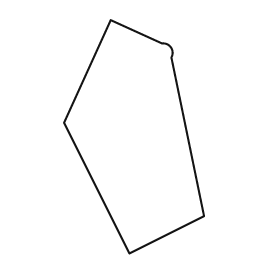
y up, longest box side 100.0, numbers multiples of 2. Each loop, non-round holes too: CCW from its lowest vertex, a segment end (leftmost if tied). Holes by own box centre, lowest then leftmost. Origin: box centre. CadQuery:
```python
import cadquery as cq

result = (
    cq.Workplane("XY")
    .moveTo(-2.0, -50.0)
    .lineTo(30.0, -34.0)
    .lineTo(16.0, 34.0)
    .threePointArc((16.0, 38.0), (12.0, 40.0))
    .lineTo(-10.0, 50.0)
    .lineTo(-30.0, 6.0)
    .close()
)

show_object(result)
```